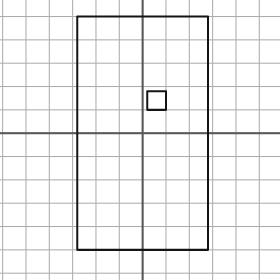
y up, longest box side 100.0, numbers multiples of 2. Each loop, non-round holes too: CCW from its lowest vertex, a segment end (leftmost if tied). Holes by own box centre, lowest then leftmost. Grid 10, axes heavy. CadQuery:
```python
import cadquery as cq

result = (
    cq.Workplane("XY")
    .moveTo(-28.0, -50.0)
    .lineTo(28.0, -50.0)
    .lineTo(28.0, 50.0)
    .lineTo(-28.0, 50.0)
    .close()
    .moveTo(2.0, 10.0)
    .lineTo(10.0, 10.0)
    .lineTo(10.0, 18.0)
    .lineTo(2.0, 18.0)
    .close()
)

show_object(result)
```